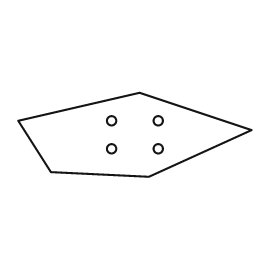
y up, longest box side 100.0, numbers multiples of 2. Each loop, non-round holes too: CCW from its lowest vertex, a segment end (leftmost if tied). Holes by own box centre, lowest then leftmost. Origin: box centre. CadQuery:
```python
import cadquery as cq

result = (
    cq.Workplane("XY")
    .moveTo(6.0, -18.0)
    .lineTo(50.0, 2.0)
    .lineTo(2.0, 18.0)
    .lineTo(-50.0, 6.0)
    .lineTo(-36.0, -16.0)
    .close()
    .moveTo(-10.0, -6.0)
    .circle(2.0)
    .moveTo(10.0, -6.0)
    .circle(2.0)
    .moveTo(-10.0, 6.0)
    .circle(2.0)
    .moveTo(10.0, 6.0)
    .circle(2.0)
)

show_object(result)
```